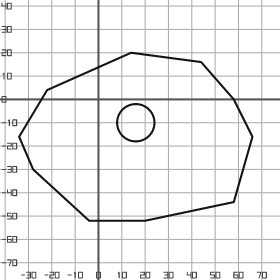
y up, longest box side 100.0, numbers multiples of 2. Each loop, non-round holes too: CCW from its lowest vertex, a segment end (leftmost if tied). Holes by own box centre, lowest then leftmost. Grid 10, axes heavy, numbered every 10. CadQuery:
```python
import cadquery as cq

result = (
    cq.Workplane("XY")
    .moveTo(-4.0, -52.0)
    .lineTo(20.0, -52.0)
    .lineTo(58.0, -44.0)
    .lineTo(66.0, -16.0)
    .lineTo(58.0, 0.0)
    .lineTo(44.0, 16.0)
    .lineTo(14.0, 20.0)
    .lineTo(-22.0, 4.0)
    .lineTo(-34.0, -16.0)
    .lineTo(-28.0, -30.0)
    .close()
    .moveTo(16.0, -10.0)
    .circle(8.0)
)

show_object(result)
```